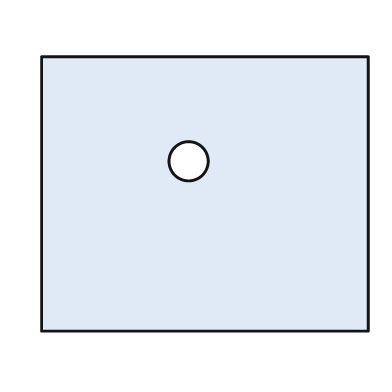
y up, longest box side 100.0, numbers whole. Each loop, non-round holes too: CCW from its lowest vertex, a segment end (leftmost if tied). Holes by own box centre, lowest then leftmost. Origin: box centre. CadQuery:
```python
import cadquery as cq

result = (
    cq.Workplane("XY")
    .moveTo(-50.0, -42.0)
    .lineTo(50.0, -42.0)
    .lineTo(50.0, 42.0)
    .lineTo(-50.0, 42.0)
    .close()
    .moveTo(-5.0, 10.0)
    .circle(6.0)
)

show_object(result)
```